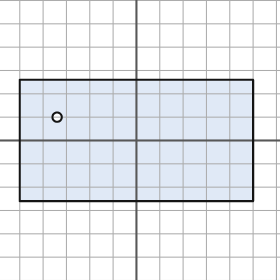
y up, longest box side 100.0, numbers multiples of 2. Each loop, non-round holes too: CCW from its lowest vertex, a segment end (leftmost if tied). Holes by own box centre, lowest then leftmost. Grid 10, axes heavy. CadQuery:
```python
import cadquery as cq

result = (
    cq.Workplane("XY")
    .moveTo(-50.0, -26.0)
    .lineTo(50.0, -26.0)
    .lineTo(50.0, 26.0)
    .lineTo(-50.0, 26.0)
    .close()
    .moveTo(-34.0, 10.0)
    .circle(2.0)
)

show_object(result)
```